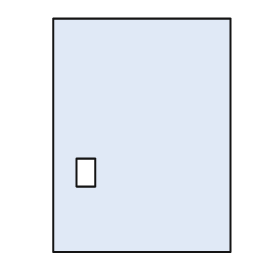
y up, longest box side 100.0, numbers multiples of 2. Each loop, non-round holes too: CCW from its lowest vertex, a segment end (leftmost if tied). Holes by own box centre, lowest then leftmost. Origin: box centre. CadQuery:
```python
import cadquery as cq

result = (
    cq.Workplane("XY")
    .moveTo(-38.0, -50.0)
    .lineTo(38.0, -50.0)
    .lineTo(38.0, 50.0)
    .lineTo(-38.0, 50.0)
    .close()
    .moveTo(-28.0, -22.0)
    .lineTo(-20.0, -22.0)
    .lineTo(-20.0, -10.0)
    .lineTo(-28.0, -10.0)
    .close()
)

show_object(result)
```